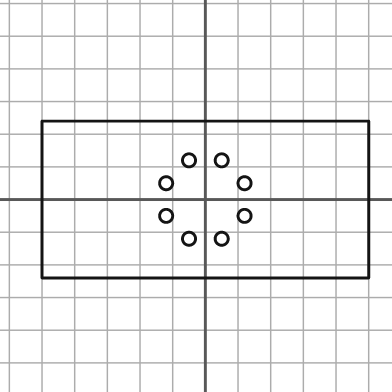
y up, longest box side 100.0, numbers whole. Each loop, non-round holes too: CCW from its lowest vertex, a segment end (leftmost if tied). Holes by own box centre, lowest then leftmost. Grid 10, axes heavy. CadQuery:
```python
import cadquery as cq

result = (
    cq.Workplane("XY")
    .moveTo(-50.0, -24.0)
    .lineTo(50.0, -24.0)
    .lineTo(50.0, 24.0)
    .lineTo(-50.0, 24.0)
    .close()
    .moveTo(-5.0, -12.0)
    .circle(2.0)
    .moveTo(5.0, -12.0)
    .circle(2.0)
    .moveTo(-12.0, -5.0)
    .circle(2.0)
    .moveTo(12.0, -5.0)
    .circle(2.0)
    .moveTo(-12.0, 5.0)
    .circle(2.0)
    .moveTo(12.0, 5.0)
    .circle(2.0)
    .moveTo(-5.0, 12.0)
    .circle(2.0)
    .moveTo(5.0, 12.0)
    .circle(2.0)
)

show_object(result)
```